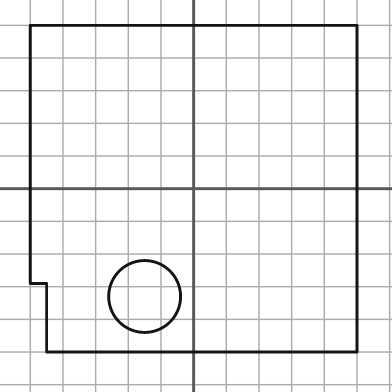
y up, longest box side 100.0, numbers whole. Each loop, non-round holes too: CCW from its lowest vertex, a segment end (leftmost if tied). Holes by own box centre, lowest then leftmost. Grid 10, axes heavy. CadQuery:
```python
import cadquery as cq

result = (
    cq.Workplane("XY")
    .moveTo(-45.0, -50.0)
    .lineTo(50.0, -50.0)
    .lineTo(50.0, 50.0)
    .lineTo(-50.0, 50.0)
    .lineTo(-50.0, -29.0)
    .lineTo(-45.0, -29.0)
    .close()
    .moveTo(-15.0, -33.0)
    .circle(11.0)
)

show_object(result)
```